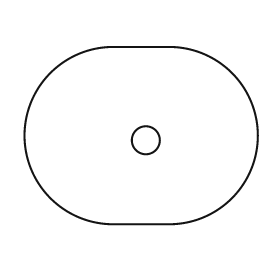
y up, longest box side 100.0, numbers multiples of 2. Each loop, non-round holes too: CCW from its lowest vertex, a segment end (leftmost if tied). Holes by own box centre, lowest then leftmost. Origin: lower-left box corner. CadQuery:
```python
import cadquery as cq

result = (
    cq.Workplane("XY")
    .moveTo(38.0, 0.0)
    .lineTo(62.0, 0.0)
    .threePointArc((100.0, 38.0), (62.0, 76.0))
    .lineTo(38.0, 76.0)
    .threePointArc((0.0, 38.0), (38.0, 0.0))
    .close()
    .moveTo(52.0, 36.0)
    .circle(6.0)
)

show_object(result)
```